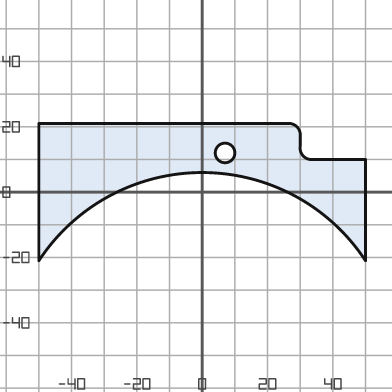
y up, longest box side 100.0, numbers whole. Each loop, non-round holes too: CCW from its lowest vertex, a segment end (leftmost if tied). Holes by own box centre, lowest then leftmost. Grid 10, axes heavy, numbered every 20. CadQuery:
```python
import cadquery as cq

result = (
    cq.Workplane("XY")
    .moveTo(-50.0, -21.0)
    .threePointArc((0.0, 6.0), (50.0, -21.0))
    .lineTo(50.0, 10.0)
    .lineTo(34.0, 10.0)
    .threePointArc((31.0, 11.0), (30.0, 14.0))
    .lineTo(30.0, 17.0)
    .threePointArc((29.0, 20.0), (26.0, 21.0))
    .lineTo(-50.0, 21.0)
    .close()
    .moveTo(7.0, 12.0)
    .circle(3.0)
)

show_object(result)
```